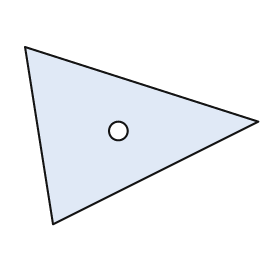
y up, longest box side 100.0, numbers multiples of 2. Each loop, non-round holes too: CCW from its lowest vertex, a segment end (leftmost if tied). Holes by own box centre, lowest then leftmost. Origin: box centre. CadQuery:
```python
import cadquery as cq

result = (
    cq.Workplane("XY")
    .moveTo(-38.0, -38.0)
    .lineTo(50.0, 6.0)
    .lineTo(-50.0, 38.0)
    .close()
    .moveTo(-10.0, 2.0)
    .circle(4.0)
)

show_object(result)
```